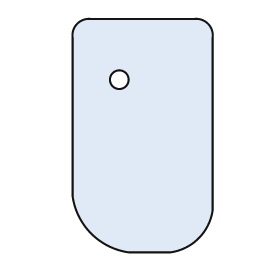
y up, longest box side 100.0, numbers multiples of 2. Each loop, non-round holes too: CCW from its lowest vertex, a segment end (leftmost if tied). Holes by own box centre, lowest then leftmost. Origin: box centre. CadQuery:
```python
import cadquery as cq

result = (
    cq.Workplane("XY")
    .moveTo(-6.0, -50.0)
    .lineTo(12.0, -50.0)
    .threePointArc((24.0, -44.0), (30.0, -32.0))
    .lineTo(30.0, 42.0)
    .threePointArc((28.0, 48.0), (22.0, 50.0))
    .lineTo(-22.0, 50.0)
    .threePointArc((-28.0, 48.0), (-30.0, 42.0))
    .lineTo(-30.0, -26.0)
    .threePointArc((-22.0, -42.0), (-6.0, -50.0))
    .close()
    .moveTo(-10.0, 24.0)
    .circle(4.0)
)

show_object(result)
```